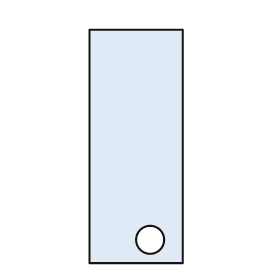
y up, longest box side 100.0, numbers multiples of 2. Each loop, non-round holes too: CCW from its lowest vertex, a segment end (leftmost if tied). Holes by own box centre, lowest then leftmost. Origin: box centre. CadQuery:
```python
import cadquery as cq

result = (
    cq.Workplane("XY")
    .moveTo(-20.0, -50.0)
    .lineTo(20.0, -50.0)
    .lineTo(20.0, 50.0)
    .lineTo(-20.0, 50.0)
    .close()
    .moveTo(6.0, -40.0)
    .circle(6.0)
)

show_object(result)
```